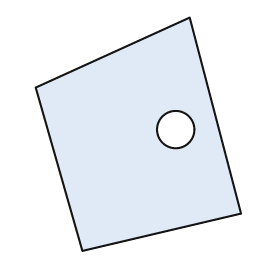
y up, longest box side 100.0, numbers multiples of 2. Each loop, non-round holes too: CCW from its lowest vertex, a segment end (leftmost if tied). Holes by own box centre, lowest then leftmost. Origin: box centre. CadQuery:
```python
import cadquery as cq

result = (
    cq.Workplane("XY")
    .moveTo(-24.0, -50.0)
    .lineTo(44.0, -34.0)
    .lineTo(22.0, 50.0)
    .lineTo(-44.0, 20.0)
    .close()
    .moveTo(16.0, 2.0)
    .circle(8.0)
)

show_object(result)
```